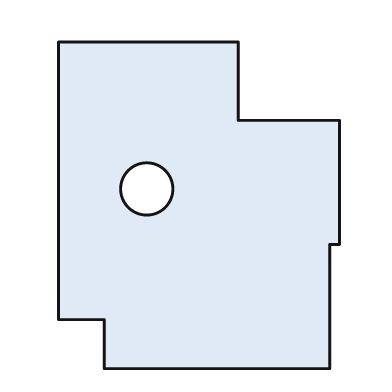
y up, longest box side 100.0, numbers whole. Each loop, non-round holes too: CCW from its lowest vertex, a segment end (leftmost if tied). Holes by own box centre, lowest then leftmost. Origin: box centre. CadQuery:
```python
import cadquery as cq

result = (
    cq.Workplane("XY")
    .moveTo(-29.0, -50.0)
    .lineTo(40.0, -50.0)
    .lineTo(40.0, -12.0)
    .lineTo(43.0, -12.0)
    .lineTo(43.0, 26.0)
    .lineTo(12.0, 26.0)
    .lineTo(12.0, 50.0)
    .lineTo(-43.0, 50.0)
    .lineTo(-43.0, -35.0)
    .lineTo(-29.0, -35.0)
    .close()
    .moveTo(-16.0, 5.0)
    .circle(8.0)
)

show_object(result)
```